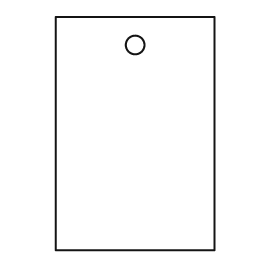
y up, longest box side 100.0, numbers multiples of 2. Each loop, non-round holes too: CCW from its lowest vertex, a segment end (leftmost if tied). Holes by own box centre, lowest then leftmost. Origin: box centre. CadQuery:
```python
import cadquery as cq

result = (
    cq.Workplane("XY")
    .moveTo(-34.0, -50.0)
    .lineTo(34.0, -50.0)
    .lineTo(34.0, 50.0)
    .lineTo(-34.0, 50.0)
    .close()
    .moveTo(0.0, 38.0)
    .circle(4.0)
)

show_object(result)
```